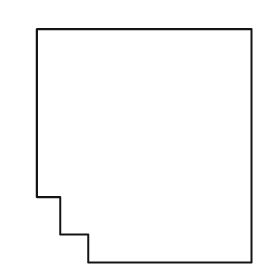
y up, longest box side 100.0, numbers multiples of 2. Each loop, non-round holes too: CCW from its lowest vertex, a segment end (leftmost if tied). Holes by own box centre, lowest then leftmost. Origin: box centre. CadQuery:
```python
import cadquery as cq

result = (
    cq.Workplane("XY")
    .moveTo(-24.0, -50.0)
    .lineTo(46.0, -50.0)
    .lineTo(46.0, 50.0)
    .lineTo(-46.0, 50.0)
    .lineTo(-46.0, -22.0)
    .lineTo(-36.0, -22.0)
    .lineTo(-36.0, -38.0)
    .lineTo(-24.0, -38.0)
    .close()
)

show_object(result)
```